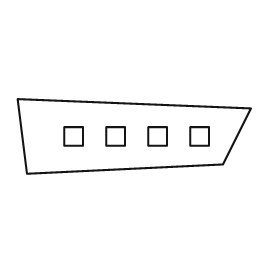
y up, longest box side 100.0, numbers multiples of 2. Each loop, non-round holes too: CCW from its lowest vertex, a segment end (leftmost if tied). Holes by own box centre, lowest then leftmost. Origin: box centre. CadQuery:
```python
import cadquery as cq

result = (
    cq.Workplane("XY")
    .moveTo(-46.0, -16.0)
    .lineTo(38.0, -12.0)
    .lineTo(50.0, 12.0)
    .lineTo(-50.0, 16.0)
    .close()
    .moveTo(-30.0, -4.0)
    .lineTo(-22.0, -4.0)
    .lineTo(-22.0, 4.0)
    .lineTo(-30.0, 4.0)
    .close()
    .moveTo(-12.0, -4.0)
    .lineTo(-4.0, -4.0)
    .lineTo(-4.0, 4.0)
    .lineTo(-12.0, 4.0)
    .close()
    .moveTo(6.0, -4.0)
    .lineTo(14.0, -4.0)
    .lineTo(14.0, 4.0)
    .lineTo(6.0, 4.0)
    .close()
    .moveTo(24.0, -4.0)
    .lineTo(32.0, -4.0)
    .lineTo(32.0, 4.0)
    .lineTo(24.0, 4.0)
    .close()
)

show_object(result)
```